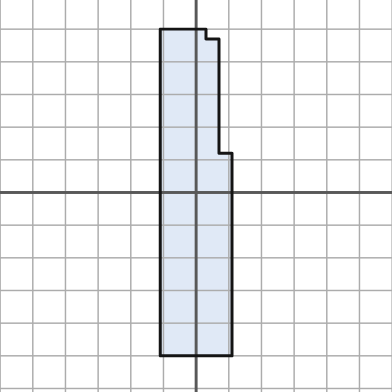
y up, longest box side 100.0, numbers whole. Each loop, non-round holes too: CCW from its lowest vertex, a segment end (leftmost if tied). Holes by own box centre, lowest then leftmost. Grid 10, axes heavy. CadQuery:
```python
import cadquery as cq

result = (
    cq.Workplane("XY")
    .moveTo(-11.0, -50.0)
    .lineTo(11.0, -50.0)
    .lineTo(11.0, 12.0)
    .lineTo(7.0, 12.0)
    .lineTo(7.0, 47.0)
    .lineTo(3.0, 47.0)
    .lineTo(3.0, 50.0)
    .lineTo(-11.0, 50.0)
    .close()
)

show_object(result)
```